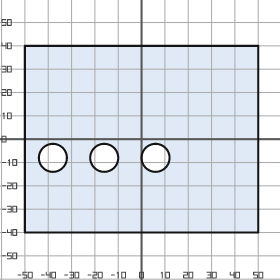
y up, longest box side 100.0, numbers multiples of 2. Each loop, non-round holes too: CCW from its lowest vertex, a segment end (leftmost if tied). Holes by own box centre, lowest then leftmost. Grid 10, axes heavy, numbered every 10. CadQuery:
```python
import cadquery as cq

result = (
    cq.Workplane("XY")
    .moveTo(-50.0, -40.0)
    .lineTo(50.0, -40.0)
    .lineTo(50.0, 40.0)
    .lineTo(-50.0, 40.0)
    .close()
    .moveTo(-38.0, -8.0)
    .circle(6.0)
    .moveTo(-16.0, -8.0)
    .circle(6.0)
    .moveTo(6.0, -8.0)
    .circle(6.0)
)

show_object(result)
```